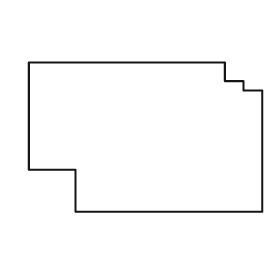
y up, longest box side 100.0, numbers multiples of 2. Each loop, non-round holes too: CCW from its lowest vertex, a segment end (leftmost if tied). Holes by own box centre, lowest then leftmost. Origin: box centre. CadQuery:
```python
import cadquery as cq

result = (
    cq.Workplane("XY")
    .moveTo(-30.0, -32.0)
    .lineTo(50.0, -32.0)
    .lineTo(50.0, 20.0)
    .lineTo(42.0, 20.0)
    .lineTo(42.0, 24.0)
    .lineTo(34.0, 24.0)
    .lineTo(34.0, 32.0)
    .lineTo(-50.0, 32.0)
    .lineTo(-50.0, -14.0)
    .lineTo(-30.0, -14.0)
    .close()
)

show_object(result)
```